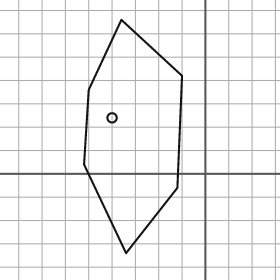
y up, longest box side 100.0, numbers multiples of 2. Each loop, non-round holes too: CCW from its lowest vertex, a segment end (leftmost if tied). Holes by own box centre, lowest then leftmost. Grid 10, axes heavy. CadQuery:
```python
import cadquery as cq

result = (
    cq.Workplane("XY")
    .moveTo(-34.0, -34.0)
    .lineTo(-12.0, -6.0)
    .lineTo(-10.0, 42.0)
    .lineTo(-36.0, 66.0)
    .lineTo(-50.0, 36.0)
    .lineTo(-52.0, 4.0)
    .close()
    .moveTo(-40.0, 24.0)
    .circle(2.0)
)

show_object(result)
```